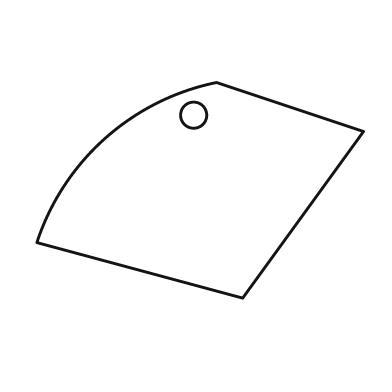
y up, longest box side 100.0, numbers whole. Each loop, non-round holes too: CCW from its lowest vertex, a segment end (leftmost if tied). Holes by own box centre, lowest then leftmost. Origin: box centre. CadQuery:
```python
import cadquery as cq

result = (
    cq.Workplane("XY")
    .moveTo(13.0, -33.0)
    .lineTo(50.0, 18.0)
    .lineTo(5.0, 33.0)
    .threePointArc((-29.0, 16.0), (-50.0, -16.0))
    .close()
    .moveTo(-2.0, 23.0)
    .circle(4.0)
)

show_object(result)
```